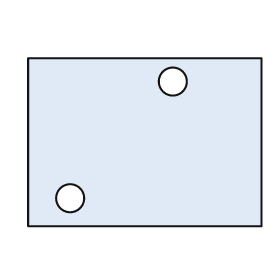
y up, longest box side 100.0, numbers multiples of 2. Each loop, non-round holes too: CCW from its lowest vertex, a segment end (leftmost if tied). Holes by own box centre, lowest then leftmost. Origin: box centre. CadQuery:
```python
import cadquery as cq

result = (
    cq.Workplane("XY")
    .moveTo(-50.0, -36.0)
    .lineTo(50.0, -36.0)
    .lineTo(50.0, 36.0)
    .lineTo(-50.0, 36.0)
    .close()
    .moveTo(-32.0, -24.0)
    .circle(6.0)
    .moveTo(12.0, 26.0)
    .circle(6.0)
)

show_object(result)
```